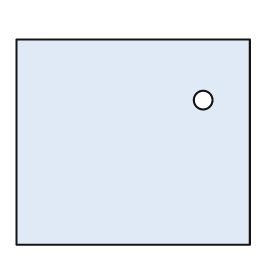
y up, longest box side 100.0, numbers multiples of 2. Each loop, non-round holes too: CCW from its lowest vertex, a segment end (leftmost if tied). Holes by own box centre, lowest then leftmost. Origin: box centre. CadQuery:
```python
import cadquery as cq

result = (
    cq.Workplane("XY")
    .moveTo(-50.0, -44.0)
    .lineTo(50.0, -44.0)
    .lineTo(50.0, 44.0)
    .lineTo(-50.0, 44.0)
    .close()
    .moveTo(30.0, 18.0)
    .circle(4.0)
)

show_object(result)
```